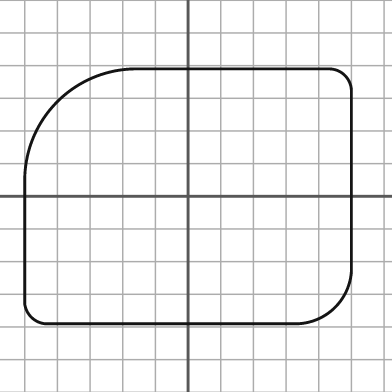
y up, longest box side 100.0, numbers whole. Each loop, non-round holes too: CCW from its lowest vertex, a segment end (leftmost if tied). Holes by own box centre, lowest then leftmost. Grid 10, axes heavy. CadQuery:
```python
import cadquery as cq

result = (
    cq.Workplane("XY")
    .moveTo(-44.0, -39.0)
    .lineTo(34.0, -39.0)
    .threePointArc((45.0, -34.0), (50.0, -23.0))
    .lineTo(50.0, 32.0)
    .threePointArc((48.0, 37.0), (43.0, 39.0))
    .lineTo(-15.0, 39.0)
    .threePointArc((-40.0, 29.0), (-50.0, 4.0))
    .lineTo(-50.0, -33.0)
    .threePointArc((-48.0, -37.0), (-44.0, -39.0))
    .close()
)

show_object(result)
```